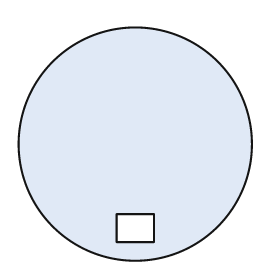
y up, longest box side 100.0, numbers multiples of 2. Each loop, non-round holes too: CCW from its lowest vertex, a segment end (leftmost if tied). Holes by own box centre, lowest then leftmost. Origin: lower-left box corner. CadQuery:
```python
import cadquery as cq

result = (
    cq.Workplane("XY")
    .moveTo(50.0, 50.0)
    .circle(50.0)
    .moveTo(42.0, 8.0)
    .lineTo(58.0, 8.0)
    .lineTo(58.0, 20.0)
    .lineTo(42.0, 20.0)
    .close()
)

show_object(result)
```